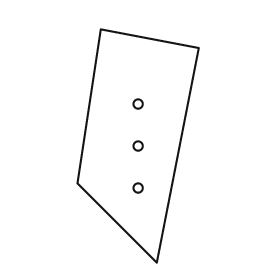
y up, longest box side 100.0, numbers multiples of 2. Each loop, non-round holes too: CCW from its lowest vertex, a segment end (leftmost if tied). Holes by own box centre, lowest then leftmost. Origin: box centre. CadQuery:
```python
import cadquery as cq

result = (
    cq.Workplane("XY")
    .moveTo(8.0, -50.0)
    .lineTo(26.0, 42.0)
    .lineTo(-16.0, 50.0)
    .lineTo(-26.0, -16.0)
    .close()
    .moveTo(0.0, -18.0)
    .circle(2.0)
    .moveTo(0.0, 0.0)
    .circle(2.0)
    .moveTo(0.0, 18.0)
    .circle(2.0)
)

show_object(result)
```